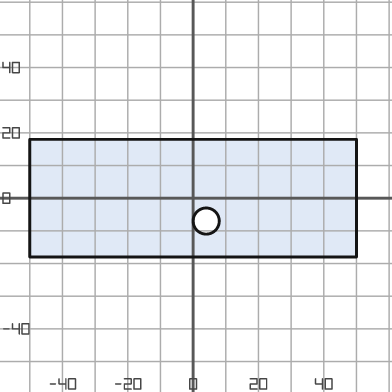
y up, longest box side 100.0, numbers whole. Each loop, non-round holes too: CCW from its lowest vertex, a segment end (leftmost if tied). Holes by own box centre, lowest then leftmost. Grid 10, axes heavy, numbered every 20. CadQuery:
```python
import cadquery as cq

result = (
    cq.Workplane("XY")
    .moveTo(-50.0, -18.0)
    .lineTo(50.0, -18.0)
    .lineTo(50.0, 18.0)
    .lineTo(-50.0, 18.0)
    .close()
    .moveTo(4.0, -7.0)
    .circle(4.0)
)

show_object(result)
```